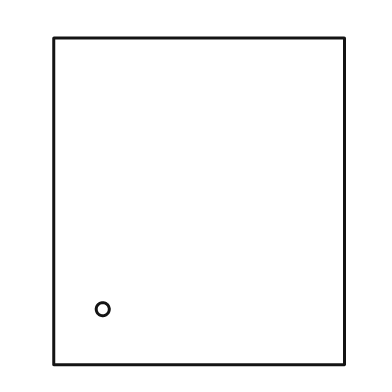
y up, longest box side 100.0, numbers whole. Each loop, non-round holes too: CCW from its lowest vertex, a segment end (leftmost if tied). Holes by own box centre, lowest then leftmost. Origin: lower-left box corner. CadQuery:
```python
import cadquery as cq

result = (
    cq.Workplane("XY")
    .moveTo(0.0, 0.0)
    .lineTo(89.0, 0.0)
    .lineTo(89.0, 100.0)
    .lineTo(0.0, 100.0)
    .close()
    .moveTo(15.0, 17.0)
    .circle(2.0)
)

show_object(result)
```